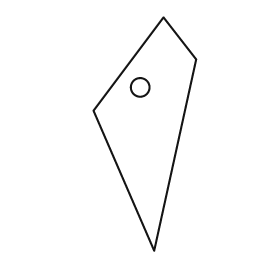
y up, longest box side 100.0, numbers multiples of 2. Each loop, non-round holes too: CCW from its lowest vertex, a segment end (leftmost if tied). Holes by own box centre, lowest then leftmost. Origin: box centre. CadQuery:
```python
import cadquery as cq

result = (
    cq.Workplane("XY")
    .moveTo(4.0, -50.0)
    .lineTo(22.0, 32.0)
    .lineTo(8.0, 50.0)
    .lineTo(-22.0, 10.0)
    .close()
    .moveTo(-2.0, 20.0)
    .circle(4.0)
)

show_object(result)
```